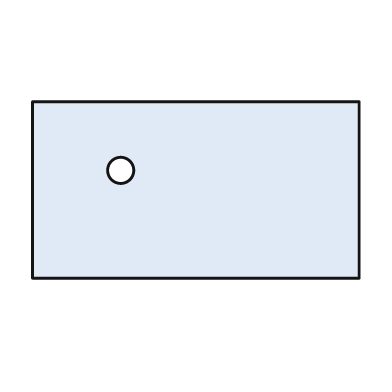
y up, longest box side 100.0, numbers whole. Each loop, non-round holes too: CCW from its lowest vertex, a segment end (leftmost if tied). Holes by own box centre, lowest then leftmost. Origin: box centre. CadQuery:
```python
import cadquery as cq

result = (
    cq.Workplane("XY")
    .moveTo(-50.0, -27.0)
    .lineTo(50.0, -27.0)
    .lineTo(50.0, 27.0)
    .lineTo(-50.0, 27.0)
    .close()
    .moveTo(-23.0, 6.0)
    .circle(4.0)
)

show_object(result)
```